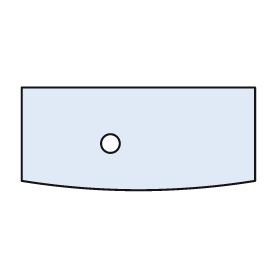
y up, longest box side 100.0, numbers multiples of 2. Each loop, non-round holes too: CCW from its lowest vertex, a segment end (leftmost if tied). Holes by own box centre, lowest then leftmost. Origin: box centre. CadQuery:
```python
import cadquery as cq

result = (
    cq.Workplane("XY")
    .moveTo(-50.0, -18.0)
    .threePointArc((0.0, -22.0), (50.0, -18.0))
    .lineTo(50.0, 22.0)
    .lineTo(-50.0, 22.0)
    .close()
    .moveTo(-12.0, -2.0)
    .circle(4.0)
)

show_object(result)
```